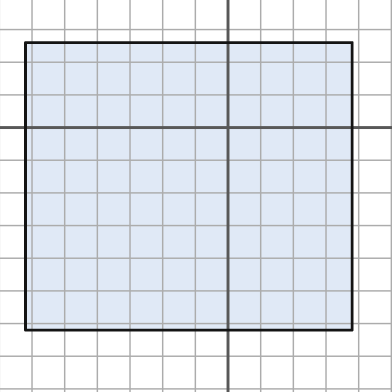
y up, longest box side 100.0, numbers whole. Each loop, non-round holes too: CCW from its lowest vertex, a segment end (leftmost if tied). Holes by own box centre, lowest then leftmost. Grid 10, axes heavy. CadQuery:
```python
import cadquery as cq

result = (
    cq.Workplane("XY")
    .moveTo(-62.0, -62.0)
    .lineTo(38.0, -62.0)
    .lineTo(38.0, 26.0)
    .lineTo(-62.0, 26.0)
    .close()
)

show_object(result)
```